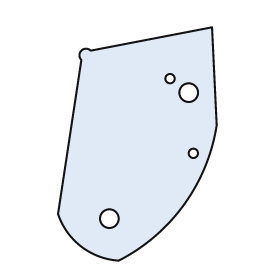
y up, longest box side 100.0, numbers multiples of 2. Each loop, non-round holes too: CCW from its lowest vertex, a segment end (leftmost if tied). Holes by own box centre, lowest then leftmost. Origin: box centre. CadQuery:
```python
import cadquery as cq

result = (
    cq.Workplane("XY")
    .moveTo(-8.0, -50.0)
    .threePointArc((20.0, -26.0), (34.0, 8.0))
    .lineTo(32.0, 50.0)
    .lineTo(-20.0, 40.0)
    .threePointArc((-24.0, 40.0), (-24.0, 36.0))
    .lineTo(-34.0, -30.0)
    .threePointArc((-24.0, -44.0), (-8.0, -50.0))
    .close()
    .moveTo(-12.0, -32.0)
    .circle(4.0)
    .moveTo(24.0, -4.0)
    .circle(2.0)
    .moveTo(22.0, 22.0)
    .circle(4.0)
    .moveTo(14.0, 28.0)
    .circle(2.0)
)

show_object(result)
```